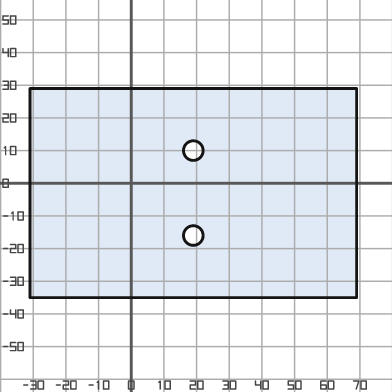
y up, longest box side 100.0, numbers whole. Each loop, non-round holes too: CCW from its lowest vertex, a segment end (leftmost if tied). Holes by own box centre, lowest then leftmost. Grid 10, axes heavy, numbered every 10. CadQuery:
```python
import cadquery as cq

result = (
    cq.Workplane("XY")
    .moveTo(-31.0, -35.0)
    .lineTo(69.0, -35.0)
    .lineTo(69.0, 29.0)
    .lineTo(-31.0, 29.0)
    .close()
    .moveTo(19.0, -16.0)
    .circle(3.0)
    .moveTo(19.0, 10.0)
    .circle(3.0)
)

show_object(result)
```